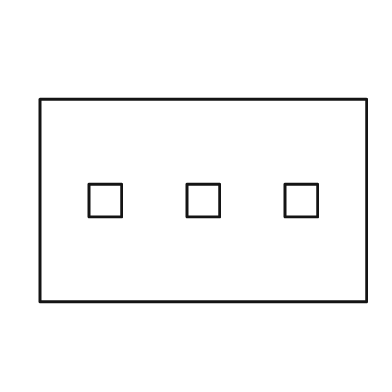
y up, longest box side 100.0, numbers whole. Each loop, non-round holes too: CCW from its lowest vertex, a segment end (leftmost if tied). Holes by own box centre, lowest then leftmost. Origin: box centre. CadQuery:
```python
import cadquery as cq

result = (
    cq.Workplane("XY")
    .moveTo(-50.0, -31.0)
    .lineTo(50.0, -31.0)
    .lineTo(50.0, 31.0)
    .lineTo(-50.0, 31.0)
    .close()
    .moveTo(-35.0, -5.0)
    .lineTo(-25.0, -5.0)
    .lineTo(-25.0, 5.0)
    .lineTo(-35.0, 5.0)
    .close()
    .moveTo(-5.0, -5.0)
    .lineTo(5.0, -5.0)
    .lineTo(5.0, 5.0)
    .lineTo(-5.0, 5.0)
    .close()
    .moveTo(25.0, -5.0)
    .lineTo(35.0, -5.0)
    .lineTo(35.0, 5.0)
    .lineTo(25.0, 5.0)
    .close()
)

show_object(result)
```